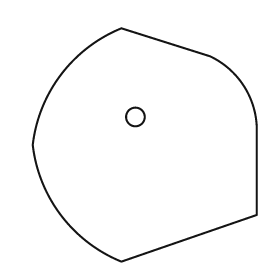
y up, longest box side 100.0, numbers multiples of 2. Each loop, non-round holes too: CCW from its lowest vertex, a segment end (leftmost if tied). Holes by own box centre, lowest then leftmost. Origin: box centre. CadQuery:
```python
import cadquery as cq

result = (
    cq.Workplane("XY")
    .moveTo(-10.0, -50.0)
    .lineTo(48.0, -30.0)
    .lineTo(48.0, 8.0)
    .threePointArc((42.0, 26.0), (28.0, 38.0))
    .lineTo(-10.0, 50.0)
    .threePointArc((-36.0, 30.0), (-48.0, 0.0))
    .threePointArc((-36.0, -30.0), (-10.0, -50.0))
    .close()
    .moveTo(-4.0, 12.0)
    .circle(4.0)
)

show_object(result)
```